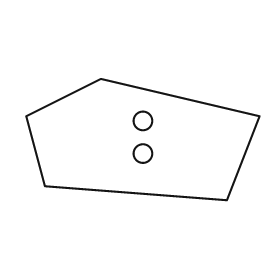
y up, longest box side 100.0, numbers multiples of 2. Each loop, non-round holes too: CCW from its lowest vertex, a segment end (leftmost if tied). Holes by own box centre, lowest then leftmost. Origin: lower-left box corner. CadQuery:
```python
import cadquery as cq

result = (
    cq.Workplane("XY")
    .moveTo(86.0, 0.0)
    .lineTo(100.0, 36.0)
    .lineTo(32.0, 52.0)
    .lineTo(0.0, 36.0)
    .lineTo(8.0, 6.0)
    .close()
    .moveTo(50.0, 20.0)
    .circle(4.0)
    .moveTo(50.0, 34.0)
    .circle(4.0)
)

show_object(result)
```